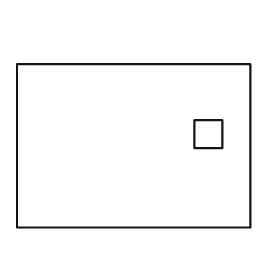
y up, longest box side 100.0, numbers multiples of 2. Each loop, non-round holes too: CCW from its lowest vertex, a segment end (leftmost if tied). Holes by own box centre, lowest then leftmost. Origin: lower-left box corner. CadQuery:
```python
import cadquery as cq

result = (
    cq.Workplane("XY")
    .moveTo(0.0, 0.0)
    .lineTo(100.0, 0.0)
    .lineTo(100.0, 70.0)
    .lineTo(0.0, 70.0)
    .close()
    .moveTo(76.0, 34.0)
    .lineTo(88.0, 34.0)
    .lineTo(88.0, 46.0)
    .lineTo(76.0, 46.0)
    .close()
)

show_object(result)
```